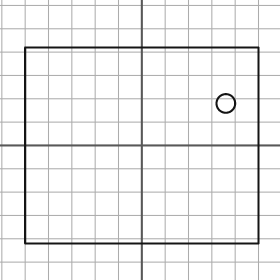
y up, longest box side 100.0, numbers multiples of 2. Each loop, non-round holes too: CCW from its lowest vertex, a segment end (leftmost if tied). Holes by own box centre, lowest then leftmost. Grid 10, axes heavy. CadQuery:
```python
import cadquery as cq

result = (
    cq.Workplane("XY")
    .moveTo(-50.0, -42.0)
    .lineTo(50.0, -42.0)
    .lineTo(50.0, 42.0)
    .lineTo(-50.0, 42.0)
    .close()
    .moveTo(36.0, 18.0)
    .circle(4.0)
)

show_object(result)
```